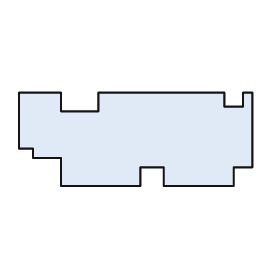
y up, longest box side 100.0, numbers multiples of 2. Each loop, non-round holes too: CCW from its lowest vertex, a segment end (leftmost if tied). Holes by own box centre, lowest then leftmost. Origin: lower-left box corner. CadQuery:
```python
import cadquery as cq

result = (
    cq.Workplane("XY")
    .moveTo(18.0, 0.0)
    .lineTo(52.0, 0.0)
    .lineTo(52.0, 8.0)
    .lineTo(62.0, 8.0)
    .lineTo(62.0, 0.0)
    .lineTo(92.0, 0.0)
    .lineTo(92.0, 8.0)
    .lineTo(100.0, 8.0)
    .lineTo(100.0, 40.0)
    .lineTo(96.0, 40.0)
    .lineTo(96.0, 34.0)
    .lineTo(88.0, 34.0)
    .lineTo(88.0, 40.0)
    .lineTo(34.0, 40.0)
    .lineTo(34.0, 32.0)
    .lineTo(18.0, 32.0)
    .lineTo(18.0, 40.0)
    .lineTo(0.0, 40.0)
    .lineTo(0.0, 16.0)
    .lineTo(6.0, 16.0)
    .lineTo(6.0, 12.0)
    .lineTo(18.0, 12.0)
    .close()
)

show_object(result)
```